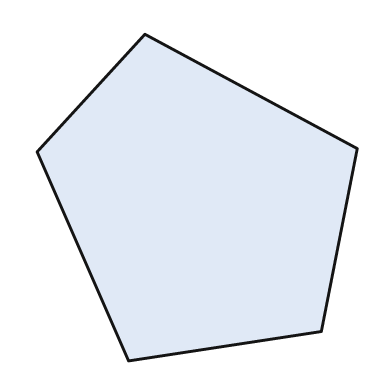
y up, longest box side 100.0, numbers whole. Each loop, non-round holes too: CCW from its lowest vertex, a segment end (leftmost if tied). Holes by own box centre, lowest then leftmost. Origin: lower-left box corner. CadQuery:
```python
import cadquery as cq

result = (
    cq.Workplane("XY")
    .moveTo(28.0, 0.0)
    .lineTo(87.0, 9.0)
    .lineTo(98.0, 65.0)
    .lineTo(33.0, 100.0)
    .lineTo(0.0, 64.0)
    .close()
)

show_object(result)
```